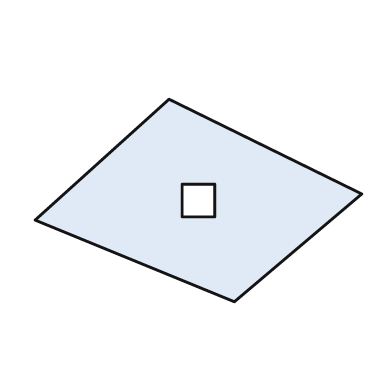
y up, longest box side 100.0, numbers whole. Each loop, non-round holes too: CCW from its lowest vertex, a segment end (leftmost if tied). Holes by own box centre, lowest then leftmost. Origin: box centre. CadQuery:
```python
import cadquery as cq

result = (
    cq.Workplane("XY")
    .moveTo(11.0, -31.0)
    .lineTo(50.0, 2.0)
    .lineTo(-9.0, 31.0)
    .lineTo(-50.0, -6.0)
    .close()
    .moveTo(-5.0, -5.0)
    .lineTo(5.0, -5.0)
    .lineTo(5.0, 5.0)
    .lineTo(-5.0, 5.0)
    .close()
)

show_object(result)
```